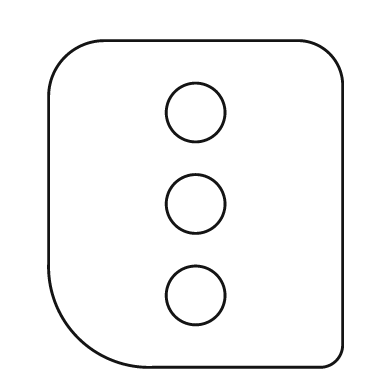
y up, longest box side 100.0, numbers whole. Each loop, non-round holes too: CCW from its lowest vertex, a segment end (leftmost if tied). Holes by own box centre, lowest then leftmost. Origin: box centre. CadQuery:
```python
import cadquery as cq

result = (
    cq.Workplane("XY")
    .moveTo(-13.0, -50.0)
    .lineTo(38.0, -50.0)
    .threePointArc((43.0, -48.0), (45.0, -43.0))
    .lineTo(45.0, 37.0)
    .threePointArc((41.0, 46.0), (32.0, 50.0))
    .lineTo(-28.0, 50.0)
    .threePointArc((-40.0, 45.0), (-45.0, 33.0))
    .lineTo(-45.0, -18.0)
    .threePointArc((-36.0, -41.0), (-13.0, -50.0))
    .close()
    .moveTo(0.0, -28.0)
    .circle(9.0)
    .moveTo(0.0, 0.0)
    .circle(9.0)
    .moveTo(0.0, 28.0)
    .circle(9.0)
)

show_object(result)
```